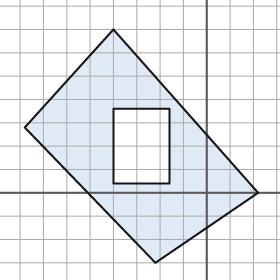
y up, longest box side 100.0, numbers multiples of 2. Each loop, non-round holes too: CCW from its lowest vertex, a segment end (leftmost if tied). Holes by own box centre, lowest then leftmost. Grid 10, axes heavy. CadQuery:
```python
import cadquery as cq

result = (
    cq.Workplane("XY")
    .moveTo(-22.0, -30.0)
    .lineTo(22.0, 0.0)
    .lineTo(-40.0, 70.0)
    .lineTo(-78.0, 28.0)
    .close()
    .moveTo(-40.0, 4.0)
    .lineTo(-16.0, 4.0)
    .lineTo(-16.0, 36.0)
    .lineTo(-40.0, 36.0)
    .close()
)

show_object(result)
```